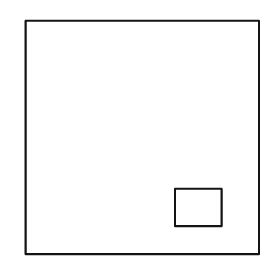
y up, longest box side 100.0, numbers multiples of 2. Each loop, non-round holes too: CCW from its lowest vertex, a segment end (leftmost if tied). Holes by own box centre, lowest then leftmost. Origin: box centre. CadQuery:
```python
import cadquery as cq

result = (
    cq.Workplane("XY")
    .moveTo(-50.0, -50.0)
    .lineTo(50.0, -50.0)
    .lineTo(50.0, 50.0)
    .lineTo(-50.0, 50.0)
    .close()
    .moveTo(14.0, -38.0)
    .lineTo(34.0, -38.0)
    .lineTo(34.0, -22.0)
    .lineTo(14.0, -22.0)
    .close()
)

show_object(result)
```